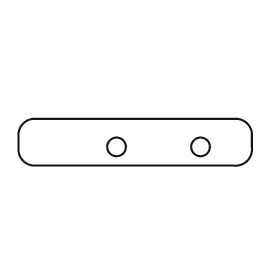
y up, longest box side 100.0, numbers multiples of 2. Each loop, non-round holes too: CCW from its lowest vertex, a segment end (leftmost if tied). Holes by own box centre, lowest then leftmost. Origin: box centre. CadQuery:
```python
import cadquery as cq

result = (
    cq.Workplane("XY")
    .moveTo(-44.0, -10.0)
    .lineTo(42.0, -10.0)
    .threePointArc((48.0, -8.0), (50.0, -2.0))
    .lineTo(50.0, 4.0)
    .threePointArc((48.0, 8.0), (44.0, 10.0))
    .lineTo(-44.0, 10.0)
    .threePointArc((-48.0, 8.0), (-50.0, 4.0))
    .lineTo(-50.0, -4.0)
    .threePointArc((-48.0, -8.0), (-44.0, -10.0))
    .close()
    .moveTo(-8.0, -2.0)
    .circle(4.0)
    .moveTo(28.0, -2.0)
    .circle(4.0)
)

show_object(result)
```